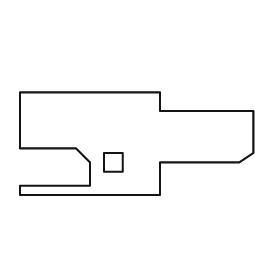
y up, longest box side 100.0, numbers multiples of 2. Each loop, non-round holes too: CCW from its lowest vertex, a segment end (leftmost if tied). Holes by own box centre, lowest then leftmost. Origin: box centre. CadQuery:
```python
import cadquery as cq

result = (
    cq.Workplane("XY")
    .moveTo(-50.0, -22.0)
    .lineTo(10.0, -22.0)
    .lineTo(10.0, -8.0)
    .lineTo(44.0, -8.0)
    .lineTo(50.0, -4.0)
    .lineTo(50.0, 14.0)
    .lineTo(10.0, 14.0)
    .lineTo(10.0, 22.0)
    .lineTo(-50.0, 22.0)
    .lineTo(-50.0, -2.0)
    .lineTo(-26.0, -2.0)
    .lineTo(-20.0, -8.0)
    .lineTo(-20.0, -18.0)
    .lineTo(-50.0, -18.0)
    .close()
    .moveTo(-14.0, -12.0)
    .lineTo(-6.0, -12.0)
    .lineTo(-6.0, -4.0)
    .lineTo(-14.0, -4.0)
    .close()
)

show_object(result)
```